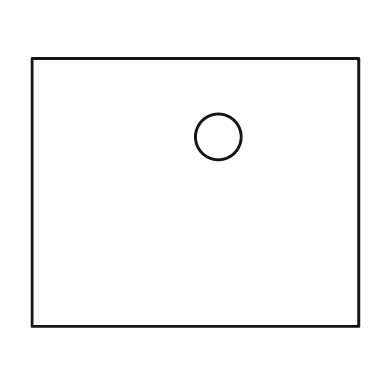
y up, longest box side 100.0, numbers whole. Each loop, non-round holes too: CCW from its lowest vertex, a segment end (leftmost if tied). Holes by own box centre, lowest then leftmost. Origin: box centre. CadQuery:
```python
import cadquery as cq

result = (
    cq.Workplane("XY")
    .moveTo(-50.0, -41.0)
    .lineTo(50.0, -41.0)
    .lineTo(50.0, 41.0)
    .lineTo(-50.0, 41.0)
    .close()
    .moveTo(7.0, 17.0)
    .circle(7.0)
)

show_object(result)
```